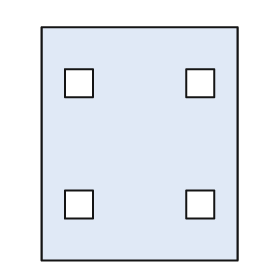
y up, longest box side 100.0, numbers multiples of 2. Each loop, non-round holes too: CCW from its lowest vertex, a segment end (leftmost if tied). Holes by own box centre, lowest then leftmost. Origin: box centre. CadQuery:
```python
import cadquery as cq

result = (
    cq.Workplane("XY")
    .moveTo(-42.0, -50.0)
    .lineTo(42.0, -50.0)
    .lineTo(42.0, 50.0)
    .lineTo(-42.0, 50.0)
    .close()
    .moveTo(-32.0, -32.0)
    .lineTo(-20.0, -32.0)
    .lineTo(-20.0, -20.0)
    .lineTo(-32.0, -20.0)
    .close()
    .moveTo(20.0, -32.0)
    .lineTo(32.0, -32.0)
    .lineTo(32.0, -20.0)
    .lineTo(20.0, -20.0)
    .close()
    .moveTo(-32.0, 20.0)
    .lineTo(-20.0, 20.0)
    .lineTo(-20.0, 32.0)
    .lineTo(-32.0, 32.0)
    .close()
    .moveTo(20.0, 20.0)
    .lineTo(32.0, 20.0)
    .lineTo(32.0, 32.0)
    .lineTo(20.0, 32.0)
    .close()
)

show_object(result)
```